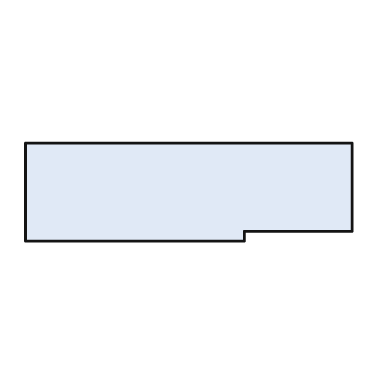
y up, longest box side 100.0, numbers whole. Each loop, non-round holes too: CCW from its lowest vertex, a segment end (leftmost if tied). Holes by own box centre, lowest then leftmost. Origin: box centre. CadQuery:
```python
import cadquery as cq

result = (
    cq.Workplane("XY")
    .moveTo(-50.0, -15.0)
    .lineTo(17.0, -15.0)
    .lineTo(17.0, -12.0)
    .lineTo(50.0, -12.0)
    .lineTo(50.0, 15.0)
    .lineTo(-50.0, 15.0)
    .close()
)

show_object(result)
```